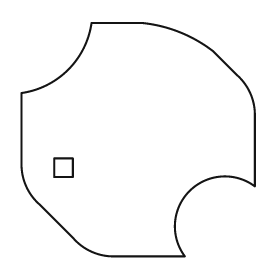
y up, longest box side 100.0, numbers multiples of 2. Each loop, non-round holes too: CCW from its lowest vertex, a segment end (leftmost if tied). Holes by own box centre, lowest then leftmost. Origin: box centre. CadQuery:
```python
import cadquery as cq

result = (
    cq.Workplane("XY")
    .moveTo(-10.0, -50.0)
    .lineTo(20.0, -50.0)
    .threePointArc((22.0, -22.0), (50.0, -20.0))
    .lineTo(50.0, 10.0)
    .threePointArc((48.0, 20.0), (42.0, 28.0))
    .lineTo(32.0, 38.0)
    .threePointArc((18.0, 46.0), (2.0, 50.0))
    .lineTo(-20.0, 50.0)
    .threePointArc((-30.0, 30.0), (-50.0, 20.0))
    .lineTo(-50.0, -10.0)
    .threePointArc((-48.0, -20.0), (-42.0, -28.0))
    .lineTo(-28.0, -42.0)
    .threePointArc((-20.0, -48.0), (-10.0, -50.0))
    .close()
    .moveTo(-36.0, -16.0)
    .lineTo(-28.0, -16.0)
    .lineTo(-28.0, -8.0)
    .lineTo(-36.0, -8.0)
    .close()
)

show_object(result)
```